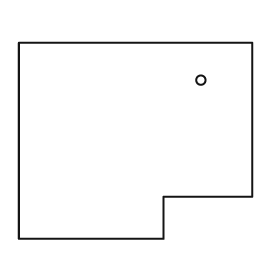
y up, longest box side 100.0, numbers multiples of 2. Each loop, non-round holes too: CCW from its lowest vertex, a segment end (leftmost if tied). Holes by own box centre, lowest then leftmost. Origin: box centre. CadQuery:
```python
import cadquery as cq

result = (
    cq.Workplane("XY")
    .moveTo(-50.0, -42.0)
    .lineTo(12.0, -42.0)
    .lineTo(12.0, -24.0)
    .lineTo(50.0, -24.0)
    .lineTo(50.0, 42.0)
    .lineTo(-50.0, 42.0)
    .close()
    .moveTo(28.0, 26.0)
    .circle(2.0)
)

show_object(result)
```